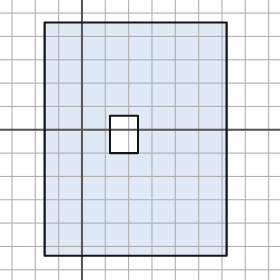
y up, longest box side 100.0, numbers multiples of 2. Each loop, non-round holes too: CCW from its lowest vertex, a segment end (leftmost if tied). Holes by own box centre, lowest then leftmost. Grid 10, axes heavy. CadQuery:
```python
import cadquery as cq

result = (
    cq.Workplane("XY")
    .moveTo(-16.0, -54.0)
    .lineTo(62.0, -54.0)
    .lineTo(62.0, 46.0)
    .lineTo(-16.0, 46.0)
    .close()
    .moveTo(12.0, -10.0)
    .lineTo(24.0, -10.0)
    .lineTo(24.0, 6.0)
    .lineTo(12.0, 6.0)
    .close()
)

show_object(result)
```